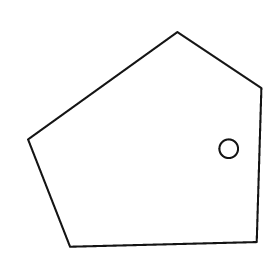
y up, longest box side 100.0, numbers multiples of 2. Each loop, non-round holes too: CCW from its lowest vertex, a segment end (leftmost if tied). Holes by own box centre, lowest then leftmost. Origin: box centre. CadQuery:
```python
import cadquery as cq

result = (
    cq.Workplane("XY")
    .moveTo(-32.0, -46.0)
    .lineTo(48.0, -44.0)
    .lineTo(50.0, 22.0)
    .lineTo(14.0, 46.0)
    .lineTo(-50.0, 0.0)
    .close()
    .moveTo(36.0, -4.0)
    .circle(4.0)
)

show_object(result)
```